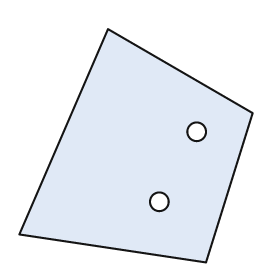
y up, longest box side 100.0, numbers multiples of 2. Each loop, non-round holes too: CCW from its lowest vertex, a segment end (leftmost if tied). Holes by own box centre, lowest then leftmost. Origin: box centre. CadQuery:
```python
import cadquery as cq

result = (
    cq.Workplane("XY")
    .moveTo(30.0, -50.0)
    .lineTo(50.0, 14.0)
    .lineTo(-12.0, 50.0)
    .lineTo(-50.0, -38.0)
    .close()
    .moveTo(10.0, -24.0)
    .circle(4.0)
    .moveTo(26.0, 6.0)
    .circle(4.0)
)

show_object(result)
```